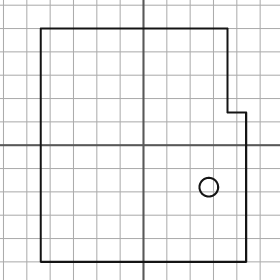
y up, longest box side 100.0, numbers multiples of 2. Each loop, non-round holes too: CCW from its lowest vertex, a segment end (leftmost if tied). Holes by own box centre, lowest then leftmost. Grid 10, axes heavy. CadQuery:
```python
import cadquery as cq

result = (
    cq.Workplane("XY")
    .moveTo(-44.0, -50.0)
    .lineTo(44.0, -50.0)
    .lineTo(44.0, 14.0)
    .lineTo(36.0, 14.0)
    .lineTo(36.0, 50.0)
    .lineTo(-44.0, 50.0)
    .close()
    .moveTo(28.0, -18.0)
    .circle(4.0)
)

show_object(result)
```